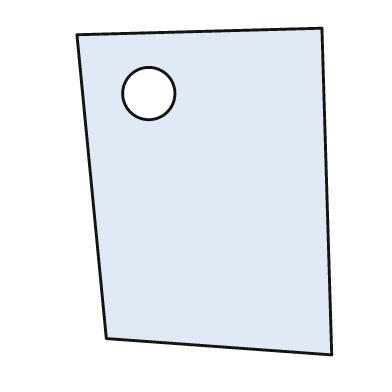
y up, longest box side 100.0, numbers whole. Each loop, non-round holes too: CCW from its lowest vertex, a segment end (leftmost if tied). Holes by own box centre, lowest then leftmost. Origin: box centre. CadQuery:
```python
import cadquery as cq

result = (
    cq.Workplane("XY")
    .moveTo(39.0, -50.0)
    .lineTo(36.0, 50.0)
    .lineTo(-39.0, 48.0)
    .lineTo(-30.0, -45.0)
    .close()
    .moveTo(-17.0, 30.0)
    .circle(8.0)
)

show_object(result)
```